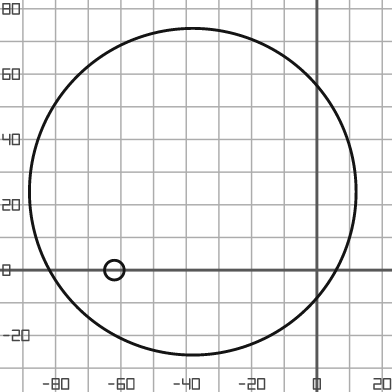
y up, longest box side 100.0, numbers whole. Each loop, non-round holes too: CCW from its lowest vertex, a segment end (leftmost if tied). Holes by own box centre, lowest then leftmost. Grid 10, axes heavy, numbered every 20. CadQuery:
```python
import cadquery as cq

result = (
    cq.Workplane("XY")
    .moveTo(-38.0, 24.0)
    .circle(50.0)
    .moveTo(-62.0, 0.0)
    .circle(3.0)
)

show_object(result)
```